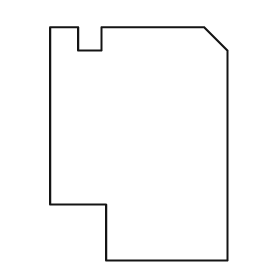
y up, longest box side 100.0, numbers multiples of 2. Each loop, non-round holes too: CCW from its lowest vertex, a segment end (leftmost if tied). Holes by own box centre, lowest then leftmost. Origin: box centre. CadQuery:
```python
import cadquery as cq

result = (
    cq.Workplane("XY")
    .moveTo(-14.0, -50.0)
    .lineTo(38.0, -50.0)
    .lineTo(38.0, 40.0)
    .lineTo(28.0, 50.0)
    .lineTo(-16.0, 50.0)
    .lineTo(-16.0, 40.0)
    .lineTo(-26.0, 40.0)
    .lineTo(-26.0, 50.0)
    .lineTo(-38.0, 50.0)
    .lineTo(-38.0, -26.0)
    .lineTo(-14.0, -26.0)
    .close()
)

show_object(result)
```